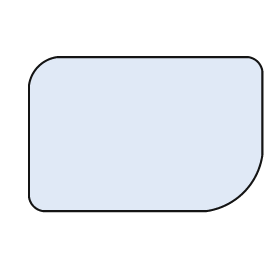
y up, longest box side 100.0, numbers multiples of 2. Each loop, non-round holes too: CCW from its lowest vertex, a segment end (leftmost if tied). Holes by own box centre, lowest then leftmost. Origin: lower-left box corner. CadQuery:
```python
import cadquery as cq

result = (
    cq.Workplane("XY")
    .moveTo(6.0, 0.0)
    .lineTo(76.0, 0.0)
    .threePointArc((92.0, 8.0), (100.0, 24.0))
    .lineTo(100.0, 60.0)
    .threePointArc((98.0, 64.0), (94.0, 66.0))
    .lineTo(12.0, 66.0)
    .threePointArc((4.0, 62.0), (0.0, 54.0))
    .lineTo(0.0, 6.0)
    .threePointArc((2.0, 2.0), (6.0, 0.0))
    .close()
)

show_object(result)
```